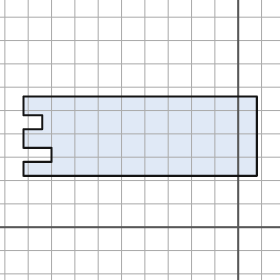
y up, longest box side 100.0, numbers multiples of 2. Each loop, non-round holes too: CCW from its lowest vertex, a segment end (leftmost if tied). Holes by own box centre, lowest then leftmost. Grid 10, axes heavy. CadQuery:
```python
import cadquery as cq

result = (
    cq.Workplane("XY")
    .moveTo(-92.0, 22.0)
    .lineTo(8.0, 22.0)
    .lineTo(8.0, 56.0)
    .lineTo(-92.0, 56.0)
    .lineTo(-92.0, 48.0)
    .lineTo(-84.0, 48.0)
    .lineTo(-84.0, 42.0)
    .lineTo(-92.0, 42.0)
    .lineTo(-92.0, 34.0)
    .lineTo(-80.0, 34.0)
    .lineTo(-80.0, 28.0)
    .lineTo(-92.0, 28.0)
    .close()
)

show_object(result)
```